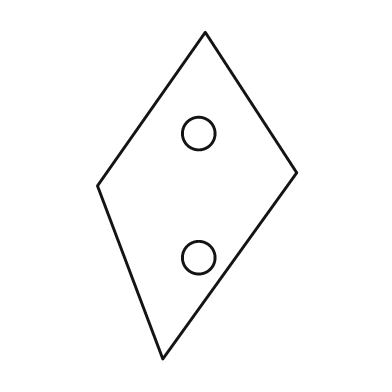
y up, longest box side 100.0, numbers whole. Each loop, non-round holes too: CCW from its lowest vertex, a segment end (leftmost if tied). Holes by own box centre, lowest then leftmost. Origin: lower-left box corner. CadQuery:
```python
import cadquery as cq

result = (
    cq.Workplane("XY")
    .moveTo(20.0, 0.0)
    .lineTo(61.0, 57.0)
    .lineTo(33.0, 100.0)
    .lineTo(0.0, 53.0)
    .close()
    .moveTo(31.0, 31.0)
    .circle(5.0)
    .moveTo(31.0, 69.0)
    .circle(5.0)
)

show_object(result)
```